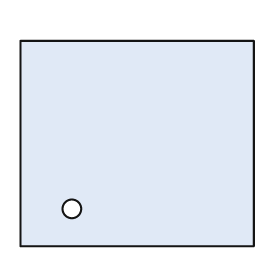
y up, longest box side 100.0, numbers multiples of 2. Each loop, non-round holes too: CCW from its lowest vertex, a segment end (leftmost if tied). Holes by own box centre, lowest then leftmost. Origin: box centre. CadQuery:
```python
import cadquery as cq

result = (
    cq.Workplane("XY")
    .moveTo(-50.0, -44.0)
    .lineTo(50.0, -44.0)
    .lineTo(50.0, 44.0)
    .lineTo(-50.0, 44.0)
    .close()
    .moveTo(-28.0, -28.0)
    .circle(4.0)
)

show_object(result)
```